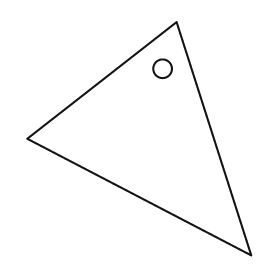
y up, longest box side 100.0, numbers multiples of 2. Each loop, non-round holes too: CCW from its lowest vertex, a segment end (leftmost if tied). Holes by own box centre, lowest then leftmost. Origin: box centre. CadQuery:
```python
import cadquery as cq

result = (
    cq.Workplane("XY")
    .moveTo(48.0, -50.0)
    .lineTo(16.0, 50.0)
    .lineTo(-48.0, 0.0)
    .close()
    .moveTo(10.0, 30.0)
    .circle(4.0)
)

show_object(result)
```